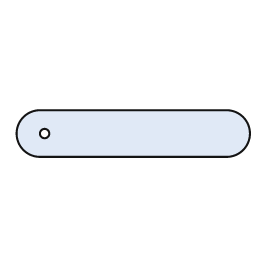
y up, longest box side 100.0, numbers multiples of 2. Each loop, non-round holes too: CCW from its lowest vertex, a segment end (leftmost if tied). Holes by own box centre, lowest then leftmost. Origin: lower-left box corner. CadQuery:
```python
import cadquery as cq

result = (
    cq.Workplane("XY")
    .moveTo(10.0, 0.0)
    .lineTo(90.0, 0.0)
    .threePointArc((100.0, 10.0), (90.0, 20.0))
    .lineTo(10.0, 20.0)
    .threePointArc((0.0, 10.0), (10.0, 0.0))
    .close()
    .moveTo(12.0, 10.0)
    .circle(2.0)
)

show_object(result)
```